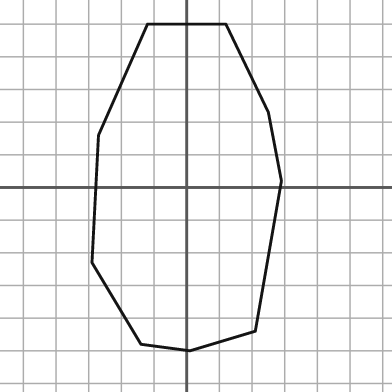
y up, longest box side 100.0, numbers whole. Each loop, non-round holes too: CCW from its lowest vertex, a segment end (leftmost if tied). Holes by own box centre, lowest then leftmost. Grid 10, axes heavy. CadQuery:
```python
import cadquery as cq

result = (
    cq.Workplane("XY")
    .moveTo(1.0, -50.0)
    .lineTo(21.0, -44.0)
    .lineTo(29.0, 2.0)
    .lineTo(25.0, 23.0)
    .lineTo(12.0, 50.0)
    .lineTo(-12.0, 50.0)
    .lineTo(-27.0, 16.0)
    .lineTo(-29.0, -23.0)
    .lineTo(-14.0, -48.0)
    .close()
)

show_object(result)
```